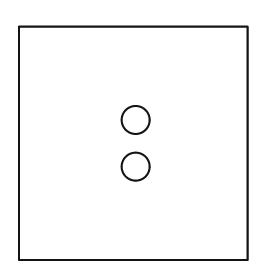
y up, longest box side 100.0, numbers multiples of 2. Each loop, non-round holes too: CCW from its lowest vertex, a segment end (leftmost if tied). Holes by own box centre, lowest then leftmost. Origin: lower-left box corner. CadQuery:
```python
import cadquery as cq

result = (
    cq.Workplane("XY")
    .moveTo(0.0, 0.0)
    .lineTo(98.0, 0.0)
    .lineTo(98.0, 100.0)
    .lineTo(0.0, 100.0)
    .close()
    .moveTo(50.0, 40.0)
    .circle(6.0)
    .moveTo(50.0, 60.0)
    .circle(6.0)
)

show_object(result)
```